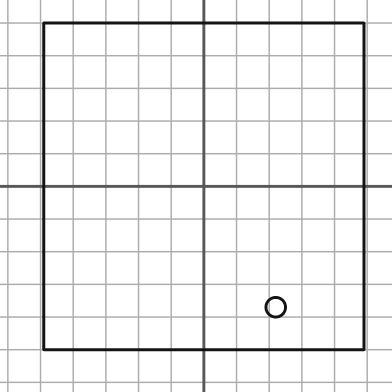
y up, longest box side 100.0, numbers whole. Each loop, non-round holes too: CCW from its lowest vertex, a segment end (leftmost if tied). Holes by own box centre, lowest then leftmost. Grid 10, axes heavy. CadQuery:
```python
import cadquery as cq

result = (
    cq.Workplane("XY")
    .moveTo(-49.0, -50.0)
    .lineTo(49.0, -50.0)
    .lineTo(49.0, 50.0)
    .lineTo(-49.0, 50.0)
    .close()
    .moveTo(22.0, -37.0)
    .circle(3.0)
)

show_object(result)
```